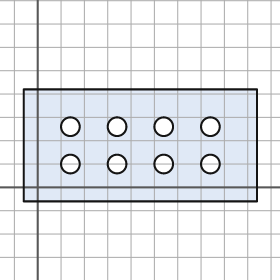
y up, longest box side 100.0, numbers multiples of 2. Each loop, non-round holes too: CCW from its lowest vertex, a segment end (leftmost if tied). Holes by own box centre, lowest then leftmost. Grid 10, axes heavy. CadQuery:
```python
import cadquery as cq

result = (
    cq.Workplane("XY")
    .moveTo(-6.0, -6.0)
    .lineTo(94.0, -6.0)
    .lineTo(94.0, 42.0)
    .lineTo(-6.0, 42.0)
    .close()
    .moveTo(14.0, 10.0)
    .circle(4.0)
    .moveTo(34.0, 10.0)
    .circle(4.0)
    .moveTo(54.0, 10.0)
    .circle(4.0)
    .moveTo(74.0, 10.0)
    .circle(4.0)
    .moveTo(14.0, 26.0)
    .circle(4.0)
    .moveTo(34.0, 26.0)
    .circle(4.0)
    .moveTo(54.0, 26.0)
    .circle(4.0)
    .moveTo(74.0, 26.0)
    .circle(4.0)
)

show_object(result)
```